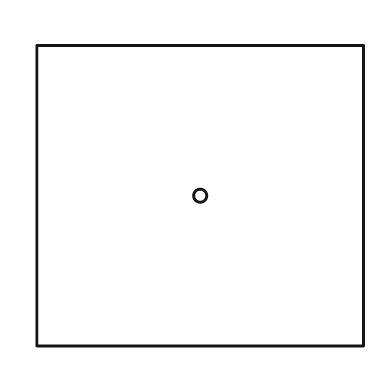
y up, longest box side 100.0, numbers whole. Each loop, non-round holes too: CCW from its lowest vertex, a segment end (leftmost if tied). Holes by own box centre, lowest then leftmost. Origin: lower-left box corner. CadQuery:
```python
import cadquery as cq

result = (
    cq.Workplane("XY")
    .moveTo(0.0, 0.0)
    .lineTo(100.0, 0.0)
    .lineTo(100.0, 92.0)
    .lineTo(0.0, 92.0)
    .close()
    .moveTo(50.0, 46.0)
    .circle(2.0)
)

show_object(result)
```